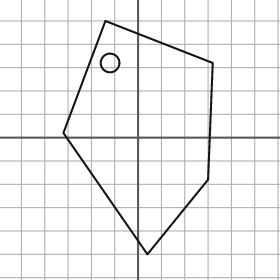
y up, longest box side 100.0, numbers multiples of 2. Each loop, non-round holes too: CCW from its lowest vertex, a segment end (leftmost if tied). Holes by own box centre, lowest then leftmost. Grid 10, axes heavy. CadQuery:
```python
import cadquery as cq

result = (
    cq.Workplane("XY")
    .moveTo(4.0, -50.0)
    .lineTo(30.0, -18.0)
    .lineTo(32.0, 32.0)
    .lineTo(-14.0, 50.0)
    .lineTo(-32.0, 2.0)
    .close()
    .moveTo(-12.0, 32.0)
    .circle(4.0)
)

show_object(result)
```